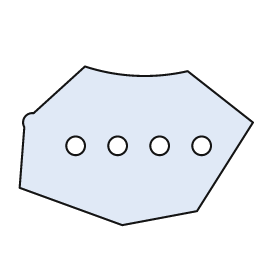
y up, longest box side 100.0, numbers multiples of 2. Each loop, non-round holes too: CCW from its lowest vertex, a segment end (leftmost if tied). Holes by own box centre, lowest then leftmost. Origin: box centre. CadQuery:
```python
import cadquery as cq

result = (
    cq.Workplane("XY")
    .moveTo(-6.0, -34.0)
    .lineTo(26.0, -28.0)
    .lineTo(50.0, 10.0)
    .lineTo(22.0, 32.0)
    .threePointArc((0.0, 30.0), (-22.0, 34.0))
    .lineTo(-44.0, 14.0)
    .threePointArc((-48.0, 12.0), (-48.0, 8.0))
    .lineTo(-50.0, -18.0)
    .close()
    .moveTo(-26.0, 0.0)
    .circle(4.0)
    .moveTo(-8.0, 0.0)
    .circle(4.0)
    .moveTo(10.0, 0.0)
    .circle(4.0)
    .moveTo(28.0, 0.0)
    .circle(4.0)
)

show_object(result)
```